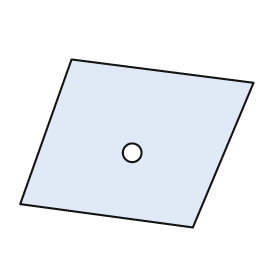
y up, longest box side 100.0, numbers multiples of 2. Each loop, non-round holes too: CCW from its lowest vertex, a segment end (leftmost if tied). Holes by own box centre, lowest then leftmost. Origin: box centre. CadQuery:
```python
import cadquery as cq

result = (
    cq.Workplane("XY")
    .moveTo(24.0, -36.0)
    .lineTo(50.0, 26.0)
    .lineTo(-28.0, 36.0)
    .lineTo(-50.0, -26.0)
    .close()
    .moveTo(-2.0, -4.0)
    .circle(4.0)
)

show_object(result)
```